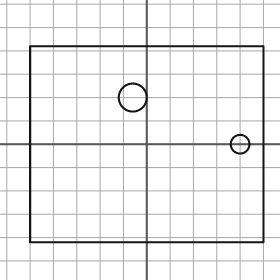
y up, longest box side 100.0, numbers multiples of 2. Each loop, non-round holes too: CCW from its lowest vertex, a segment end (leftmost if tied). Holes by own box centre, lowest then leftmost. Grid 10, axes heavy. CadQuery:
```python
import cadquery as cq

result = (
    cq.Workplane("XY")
    .moveTo(-50.0, -42.0)
    .lineTo(50.0, -42.0)
    .lineTo(50.0, 42.0)
    .lineTo(-50.0, 42.0)
    .close()
    .moveTo(40.0, 0.0)
    .circle(4.0)
    .moveTo(-6.0, 20.0)
    .circle(6.0)
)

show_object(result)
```